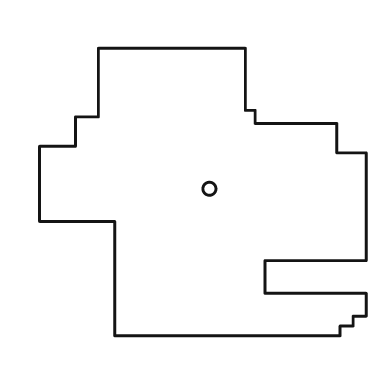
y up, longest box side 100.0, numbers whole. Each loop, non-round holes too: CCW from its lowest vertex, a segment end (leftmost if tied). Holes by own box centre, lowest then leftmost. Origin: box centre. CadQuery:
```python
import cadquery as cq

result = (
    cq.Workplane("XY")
    .moveTo(-27.0, -44.0)
    .lineTo(42.0, -44.0)
    .lineTo(42.0, -41.0)
    .lineTo(46.0, -41.0)
    .lineTo(46.0, -38.0)
    .lineTo(50.0, -38.0)
    .lineTo(50.0, -31.0)
    .lineTo(19.0, -31.0)
    .lineTo(19.0, -21.0)
    .lineTo(50.0, -21.0)
    .lineTo(50.0, 12.0)
    .lineTo(41.0, 12.0)
    .lineTo(41.0, 21.0)
    .lineTo(16.0, 21.0)
    .lineTo(16.0, 25.0)
    .lineTo(13.0, 25.0)
    .lineTo(13.0, 44.0)
    .lineTo(-32.0, 44.0)
    .lineTo(-32.0, 23.0)
    .lineTo(-39.0, 23.0)
    .lineTo(-39.0, 14.0)
    .lineTo(-50.0, 14.0)
    .lineTo(-50.0, -9.0)
    .lineTo(-27.0, -9.0)
    .close()
    .moveTo(2.0, 1.0)
    .circle(2.0)
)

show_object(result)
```